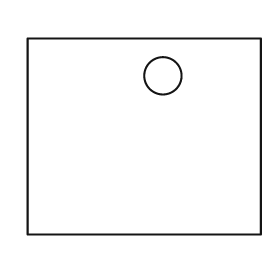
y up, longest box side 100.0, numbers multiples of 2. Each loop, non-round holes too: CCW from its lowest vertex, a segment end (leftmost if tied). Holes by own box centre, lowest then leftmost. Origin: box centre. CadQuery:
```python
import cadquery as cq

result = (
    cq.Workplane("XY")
    .moveTo(-50.0, -42.0)
    .lineTo(50.0, -42.0)
    .lineTo(50.0, 42.0)
    .lineTo(-50.0, 42.0)
    .close()
    .moveTo(8.0, 26.0)
    .circle(8.0)
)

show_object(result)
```